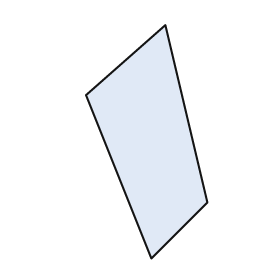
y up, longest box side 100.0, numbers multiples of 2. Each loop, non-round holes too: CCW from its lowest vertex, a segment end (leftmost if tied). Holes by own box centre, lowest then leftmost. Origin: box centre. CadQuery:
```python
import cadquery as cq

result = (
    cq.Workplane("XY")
    .moveTo(2.0, -50.0)
    .lineTo(26.0, -26.0)
    .lineTo(8.0, 50.0)
    .lineTo(-26.0, 20.0)
    .close()
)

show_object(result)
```